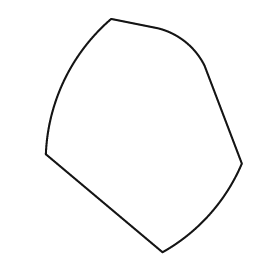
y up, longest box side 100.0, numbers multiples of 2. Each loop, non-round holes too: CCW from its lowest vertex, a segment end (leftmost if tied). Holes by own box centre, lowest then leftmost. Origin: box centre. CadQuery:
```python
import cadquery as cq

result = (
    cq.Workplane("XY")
    .moveTo(8.0, -50.0)
    .threePointArc((28.0, -34.0), (42.0, -12.0))
    .lineTo(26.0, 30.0)
    .threePointArc((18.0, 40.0), (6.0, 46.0))
    .lineTo(-14.0, 50.0)
    .threePointArc((-34.0, 24.0), (-42.0, -8.0))
    .close()
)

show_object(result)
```